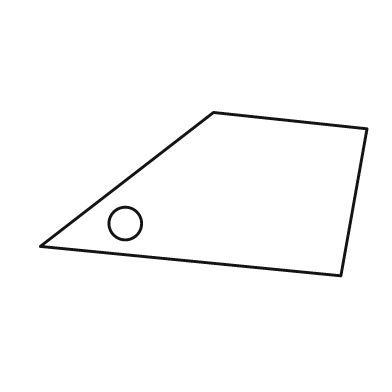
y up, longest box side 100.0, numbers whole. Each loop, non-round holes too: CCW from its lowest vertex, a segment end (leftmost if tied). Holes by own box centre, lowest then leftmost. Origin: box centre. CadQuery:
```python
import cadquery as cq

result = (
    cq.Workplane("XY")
    .moveTo(42.0, -25.0)
    .lineTo(50.0, 20.0)
    .lineTo(3.0, 25.0)
    .lineTo(-50.0, -16.0)
    .close()
    .moveTo(-24.0, -9.0)
    .circle(5.0)
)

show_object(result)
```